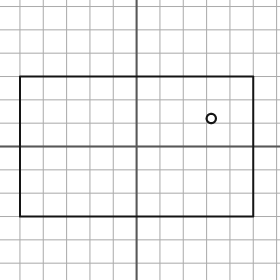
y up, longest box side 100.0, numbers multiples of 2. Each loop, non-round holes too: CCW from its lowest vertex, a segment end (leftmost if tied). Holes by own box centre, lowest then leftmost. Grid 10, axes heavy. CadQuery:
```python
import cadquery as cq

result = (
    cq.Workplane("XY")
    .moveTo(-50.0, -30.0)
    .lineTo(50.0, -30.0)
    .lineTo(50.0, 30.0)
    .lineTo(-50.0, 30.0)
    .close()
    .moveTo(32.0, 12.0)
    .circle(2.0)
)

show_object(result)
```